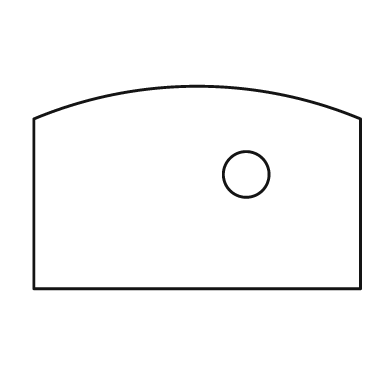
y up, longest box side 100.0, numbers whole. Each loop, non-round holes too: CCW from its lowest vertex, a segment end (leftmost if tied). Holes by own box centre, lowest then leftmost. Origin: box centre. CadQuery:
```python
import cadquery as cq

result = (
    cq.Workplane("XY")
    .moveTo(-50.0, -31.0)
    .lineTo(50.0, -31.0)
    .lineTo(50.0, 21.0)
    .threePointArc((0.0, 31.0), (-50.0, 21.0))
    .close()
    .moveTo(15.0, 4.0)
    .circle(7.0)
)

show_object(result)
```